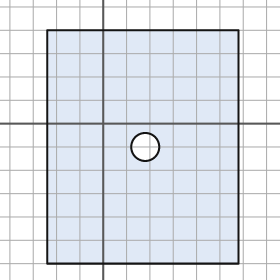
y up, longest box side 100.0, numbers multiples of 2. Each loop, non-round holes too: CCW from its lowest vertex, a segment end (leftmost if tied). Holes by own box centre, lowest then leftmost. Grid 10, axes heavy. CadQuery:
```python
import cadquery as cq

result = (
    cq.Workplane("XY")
    .moveTo(-24.0, -60.0)
    .lineTo(58.0, -60.0)
    .lineTo(58.0, 40.0)
    .lineTo(-24.0, 40.0)
    .close()
    .moveTo(18.0, -10.0)
    .circle(6.0)
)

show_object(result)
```